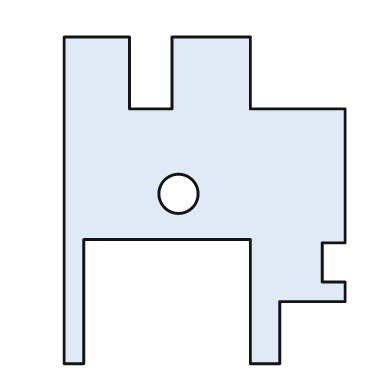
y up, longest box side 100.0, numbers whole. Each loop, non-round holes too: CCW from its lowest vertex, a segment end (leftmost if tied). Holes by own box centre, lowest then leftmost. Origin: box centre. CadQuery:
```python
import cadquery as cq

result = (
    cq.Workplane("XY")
    .moveTo(-43.0, -50.0)
    .lineTo(-37.0, -50.0)
    .lineTo(-37.0, -12.0)
    .lineTo(14.0, -12.0)
    .lineTo(14.0, -50.0)
    .lineTo(23.0, -50.0)
    .lineTo(23.0, -31.0)
    .lineTo(43.0, -31.0)
    .lineTo(43.0, -25.0)
    .lineTo(36.0, -25.0)
    .lineTo(36.0, -13.0)
    .lineTo(43.0, -13.0)
    .lineTo(43.0, 28.0)
    .lineTo(14.0, 28.0)
    .lineTo(14.0, 50.0)
    .lineTo(-10.0, 50.0)
    .lineTo(-10.0, 28.0)
    .lineTo(-23.0, 28.0)
    .lineTo(-23.0, 50.0)
    .lineTo(-43.0, 50.0)
    .close()
    .moveTo(-8.0, 2.0)
    .circle(6.0)
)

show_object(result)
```